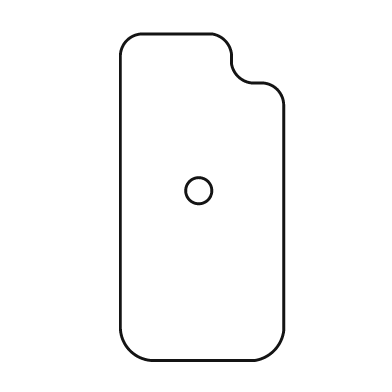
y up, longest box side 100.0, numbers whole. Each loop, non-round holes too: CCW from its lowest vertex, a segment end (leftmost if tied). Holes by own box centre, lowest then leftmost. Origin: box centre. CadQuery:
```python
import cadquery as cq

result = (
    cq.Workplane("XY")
    .moveTo(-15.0, -50.0)
    .lineTo(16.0, -50.0)
    .threePointArc((22.0, -47.0), (25.0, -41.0))
    .lineTo(25.0, 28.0)
    .threePointArc((23.0, 33.0), (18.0, 35.0))
    .lineTo(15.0, 35.0)
    .threePointArc((11.0, 37.0), (9.0, 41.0))
    .lineTo(9.0, 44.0)
    .threePointArc((7.0, 48.0), (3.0, 50.0))
    .lineTo(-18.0, 50.0)
    .threePointArc((-23.0, 48.0), (-25.0, 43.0))
    .lineTo(-25.0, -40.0)
    .threePointArc((-22.0, -47.0), (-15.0, -50.0))
    .close()
    .moveTo(-1.0, 2.0)
    .circle(4.0)
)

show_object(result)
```